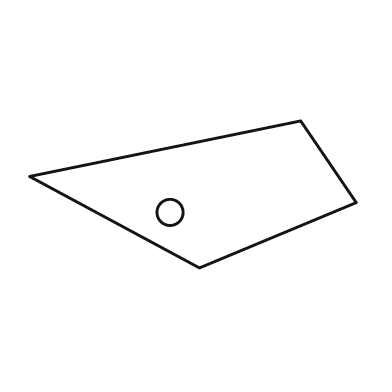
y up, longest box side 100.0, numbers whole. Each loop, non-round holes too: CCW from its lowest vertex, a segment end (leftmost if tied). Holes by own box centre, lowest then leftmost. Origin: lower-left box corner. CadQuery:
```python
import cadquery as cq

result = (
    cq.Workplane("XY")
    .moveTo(52.0, 0.0)
    .lineTo(100.0, 20.0)
    .lineTo(83.0, 45.0)
    .lineTo(0.0, 28.0)
    .close()
    .moveTo(43.0, 17.0)
    .circle(4.0)
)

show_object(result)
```